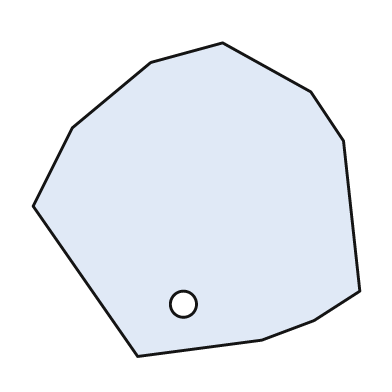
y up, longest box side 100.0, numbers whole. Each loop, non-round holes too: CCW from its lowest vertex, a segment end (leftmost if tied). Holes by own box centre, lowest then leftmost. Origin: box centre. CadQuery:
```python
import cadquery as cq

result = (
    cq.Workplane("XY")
    .moveTo(-18.0, -48.0)
    .lineTo(20.0, -43.0)
    .lineTo(36.0, -37.0)
    .lineTo(50.0, -28.0)
    .lineTo(45.0, 18.0)
    .lineTo(35.0, 33.0)
    .lineTo(8.0, 48.0)
    .lineTo(-14.0, 42.0)
    .lineTo(-38.0, 22.0)
    .lineTo(-50.0, -2.0)
    .close()
    .moveTo(-4.0, -32.0)
    .circle(4.0)
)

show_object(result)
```